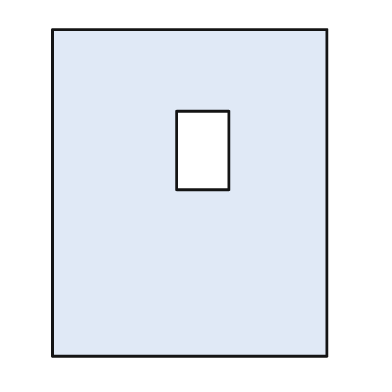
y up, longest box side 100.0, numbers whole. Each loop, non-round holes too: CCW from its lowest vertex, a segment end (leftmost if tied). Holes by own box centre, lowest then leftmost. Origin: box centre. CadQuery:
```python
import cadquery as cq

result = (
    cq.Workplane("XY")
    .moveTo(-42.0, -50.0)
    .lineTo(42.0, -50.0)
    .lineTo(42.0, 50.0)
    .lineTo(-42.0, 50.0)
    .close()
    .moveTo(-4.0, 1.0)
    .lineTo(12.0, 1.0)
    .lineTo(12.0, 25.0)
    .lineTo(-4.0, 25.0)
    .close()
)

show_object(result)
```